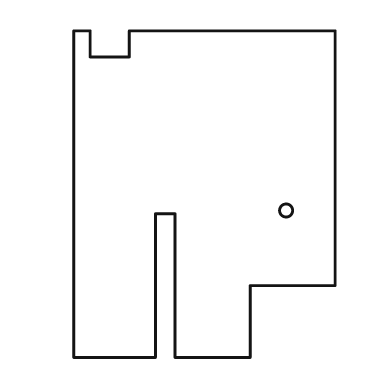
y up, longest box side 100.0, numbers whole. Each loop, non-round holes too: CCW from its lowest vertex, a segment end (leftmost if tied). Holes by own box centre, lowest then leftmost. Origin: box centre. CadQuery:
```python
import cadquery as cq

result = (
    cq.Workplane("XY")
    .moveTo(-40.0, -50.0)
    .lineTo(-15.0, -50.0)
    .lineTo(-15.0, -6.0)
    .lineTo(-9.0, -6.0)
    .lineTo(-9.0, -50.0)
    .lineTo(14.0, -50.0)
    .lineTo(14.0, -28.0)
    .lineTo(40.0, -28.0)
    .lineTo(40.0, 50.0)
    .lineTo(-23.0, 50.0)
    .lineTo(-23.0, 42.0)
    .lineTo(-35.0, 42.0)
    .lineTo(-35.0, 50.0)
    .lineTo(-40.0, 50.0)
    .close()
    .moveTo(25.0, -5.0)
    .circle(2.0)
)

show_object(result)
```